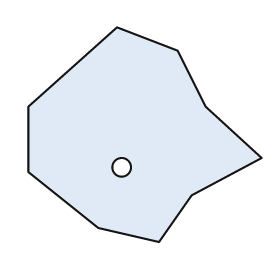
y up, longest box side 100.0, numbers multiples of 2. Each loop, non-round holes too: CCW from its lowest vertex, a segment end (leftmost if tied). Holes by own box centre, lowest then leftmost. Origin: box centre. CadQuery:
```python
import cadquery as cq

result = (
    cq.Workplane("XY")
    .moveTo(6.0, -46.0)
    .lineTo(20.0, -26.0)
    .lineTo(50.0, -10.0)
    .lineTo(26.0, 12.0)
    .lineTo(14.0, 36.0)
    .lineTo(-12.0, 46.0)
    .lineTo(-50.0, 12.0)
    .lineTo(-50.0, -16.0)
    .lineTo(-20.0, -40.0)
    .close()
    .moveTo(-10.0, -14.0)
    .circle(4.0)
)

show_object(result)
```